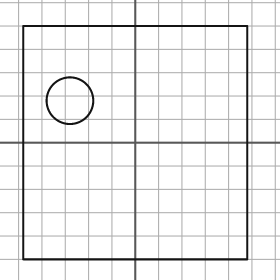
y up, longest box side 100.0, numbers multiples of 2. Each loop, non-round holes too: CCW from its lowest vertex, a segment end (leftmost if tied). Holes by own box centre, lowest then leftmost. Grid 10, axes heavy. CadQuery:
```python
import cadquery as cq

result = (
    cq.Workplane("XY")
    .moveTo(-48.0, -50.0)
    .lineTo(48.0, -50.0)
    .lineTo(48.0, 50.0)
    .lineTo(-48.0, 50.0)
    .close()
    .moveTo(-28.0, 18.0)
    .circle(10.0)
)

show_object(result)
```